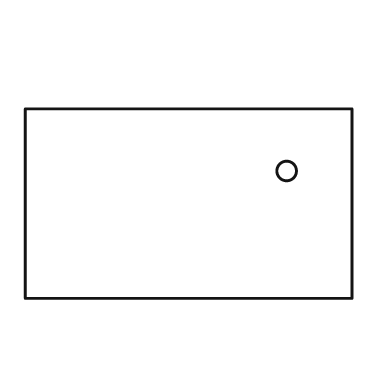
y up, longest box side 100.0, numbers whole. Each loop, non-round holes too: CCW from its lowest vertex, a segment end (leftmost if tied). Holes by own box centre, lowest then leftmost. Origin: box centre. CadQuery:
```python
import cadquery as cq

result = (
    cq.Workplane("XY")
    .moveTo(-50.0, -29.0)
    .lineTo(50.0, -29.0)
    .lineTo(50.0, 29.0)
    .lineTo(-50.0, 29.0)
    .close()
    .moveTo(30.0, 10.0)
    .circle(3.0)
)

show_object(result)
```